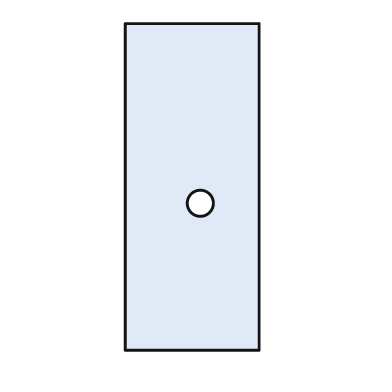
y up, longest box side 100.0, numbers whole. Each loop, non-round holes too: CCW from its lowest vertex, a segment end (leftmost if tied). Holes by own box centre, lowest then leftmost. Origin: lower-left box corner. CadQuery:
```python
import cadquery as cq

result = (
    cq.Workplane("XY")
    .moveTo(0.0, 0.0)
    .lineTo(41.0, 0.0)
    .lineTo(41.0, 100.0)
    .lineTo(0.0, 100.0)
    .close()
    .moveTo(23.0, 45.0)
    .circle(4.0)
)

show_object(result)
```